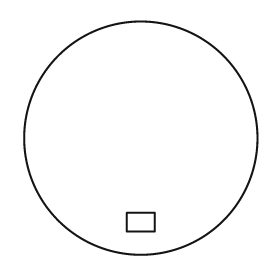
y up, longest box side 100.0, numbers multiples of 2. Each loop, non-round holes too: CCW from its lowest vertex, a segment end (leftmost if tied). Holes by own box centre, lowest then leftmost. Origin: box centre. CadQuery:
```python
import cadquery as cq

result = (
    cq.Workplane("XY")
    .moveTo(0.0, 0.0)
    .circle(50.0)
    .moveTo(-6.0, -40.0)
    .lineTo(6.0, -40.0)
    .lineTo(6.0, -32.0)
    .lineTo(-6.0, -32.0)
    .close()
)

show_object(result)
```